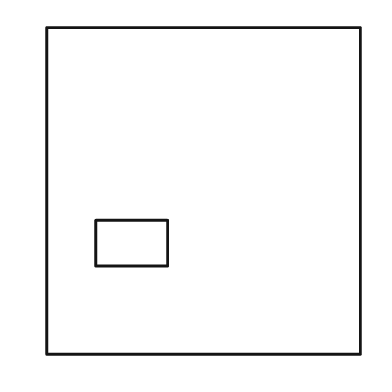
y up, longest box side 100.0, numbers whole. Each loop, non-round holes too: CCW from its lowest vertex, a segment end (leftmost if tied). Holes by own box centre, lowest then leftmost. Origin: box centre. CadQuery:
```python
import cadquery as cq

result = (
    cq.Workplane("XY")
    .moveTo(-48.0, -50.0)
    .lineTo(48.0, -50.0)
    .lineTo(48.0, 50.0)
    .lineTo(-48.0, 50.0)
    .close()
    .moveTo(-33.0, -23.0)
    .lineTo(-11.0, -23.0)
    .lineTo(-11.0, -9.0)
    .lineTo(-33.0, -9.0)
    .close()
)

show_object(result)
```